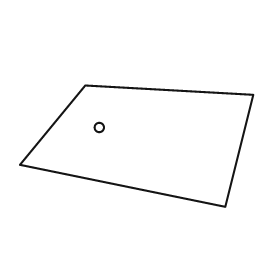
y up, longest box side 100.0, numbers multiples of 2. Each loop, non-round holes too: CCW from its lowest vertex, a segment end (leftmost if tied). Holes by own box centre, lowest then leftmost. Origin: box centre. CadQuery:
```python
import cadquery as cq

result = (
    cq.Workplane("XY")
    .moveTo(38.0, -26.0)
    .lineTo(50.0, 22.0)
    .lineTo(-22.0, 26.0)
    .lineTo(-50.0, -8.0)
    .close()
    .moveTo(-16.0, 8.0)
    .circle(2.0)
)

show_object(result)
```